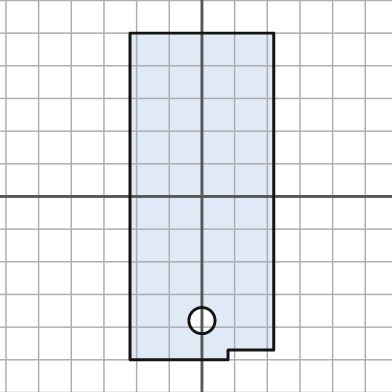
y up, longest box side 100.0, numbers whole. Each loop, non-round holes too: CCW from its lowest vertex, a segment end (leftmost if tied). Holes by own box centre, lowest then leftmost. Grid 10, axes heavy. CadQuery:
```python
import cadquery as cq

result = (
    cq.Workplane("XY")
    .moveTo(-22.0, -50.0)
    .lineTo(8.0, -50.0)
    .lineTo(8.0, -47.0)
    .lineTo(22.0, -47.0)
    .lineTo(22.0, 50.0)
    .lineTo(-22.0, 50.0)
    .close()
    .moveTo(0.0, -38.0)
    .circle(4.0)
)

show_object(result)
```